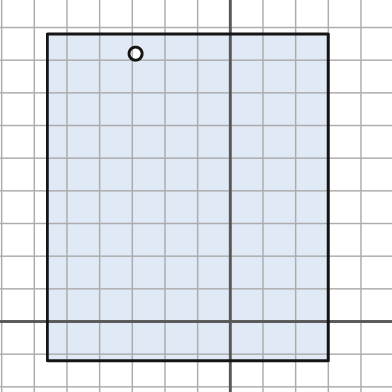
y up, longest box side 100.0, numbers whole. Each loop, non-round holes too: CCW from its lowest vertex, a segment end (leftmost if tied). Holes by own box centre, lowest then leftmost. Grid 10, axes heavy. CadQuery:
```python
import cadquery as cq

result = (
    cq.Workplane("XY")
    .moveTo(-56.0, -12.0)
    .lineTo(30.0, -12.0)
    .lineTo(30.0, 88.0)
    .lineTo(-56.0, 88.0)
    .close()
    .moveTo(-29.0, 82.0)
    .circle(2.0)
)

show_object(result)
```